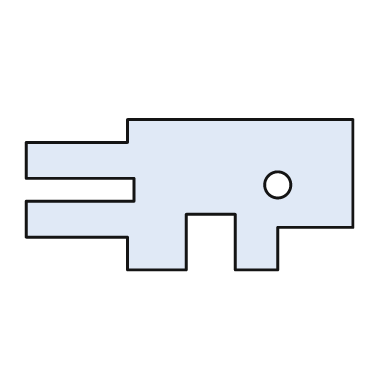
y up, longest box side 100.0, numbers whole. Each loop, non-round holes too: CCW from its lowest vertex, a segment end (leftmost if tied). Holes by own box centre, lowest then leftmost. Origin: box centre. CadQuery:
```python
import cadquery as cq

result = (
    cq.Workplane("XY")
    .moveTo(-19.0, -23.0)
    .lineTo(-1.0, -23.0)
    .lineTo(-1.0, -6.0)
    .lineTo(14.0, -6.0)
    .lineTo(14.0, -23.0)
    .lineTo(27.0, -23.0)
    .lineTo(27.0, -10.0)
    .lineTo(50.0, -10.0)
    .lineTo(50.0, 23.0)
    .lineTo(-19.0, 23.0)
    .lineTo(-19.0, 16.0)
    .lineTo(-50.0, 16.0)
    .lineTo(-50.0, 5.0)
    .lineTo(-17.0, 5.0)
    .lineTo(-17.0, -2.0)
    .lineTo(-50.0, -2.0)
    .lineTo(-50.0, -13.0)
    .lineTo(-19.0, -13.0)
    .close()
    .moveTo(27.0, 3.0)
    .circle(4.0)
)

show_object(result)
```